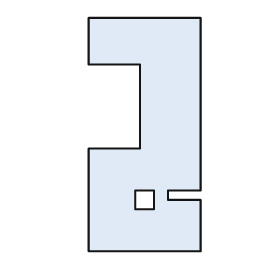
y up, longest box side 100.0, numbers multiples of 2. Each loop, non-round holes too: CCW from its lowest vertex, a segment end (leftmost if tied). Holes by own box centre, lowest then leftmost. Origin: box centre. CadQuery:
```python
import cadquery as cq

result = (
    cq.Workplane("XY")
    .moveTo(-24.0, -50.0)
    .lineTo(24.0, -50.0)
    .lineTo(24.0, -28.0)
    .lineTo(10.0, -28.0)
    .lineTo(10.0, -24.0)
    .lineTo(24.0, -24.0)
    .lineTo(24.0, 50.0)
    .lineTo(-24.0, 50.0)
    .lineTo(-24.0, 30.0)
    .lineTo(-2.0, 30.0)
    .lineTo(-2.0, -6.0)
    .lineTo(-24.0, -6.0)
    .close()
    .moveTo(-4.0, -32.0)
    .lineTo(4.0, -32.0)
    .lineTo(4.0, -24.0)
    .lineTo(-4.0, -24.0)
    .close()
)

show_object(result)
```